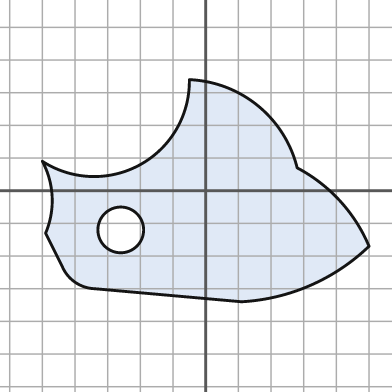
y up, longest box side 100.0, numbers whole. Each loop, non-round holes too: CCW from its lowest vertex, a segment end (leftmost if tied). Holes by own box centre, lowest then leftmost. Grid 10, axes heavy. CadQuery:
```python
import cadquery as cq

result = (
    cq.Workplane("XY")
    .moveTo(11.0, -34.0)
    .threePointArc((32.0, -29.0), (50.0, -17.0))
    .threePointArc((41.0, -3.0), (28.0, 7.0))
    .threePointArc((16.0, 26.0), (-5.0, 34.0))
    .threePointArc((-20.0, 8.0), (-50.0, 9.0))
    .threePointArc((-47.0, -2.0), (-49.0, -13.0))
    .lineTo(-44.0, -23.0)
    .threePointArc((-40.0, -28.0), (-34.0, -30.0))
    .close()
    .moveTo(-26.0, -12.0)
    .circle(7.0)
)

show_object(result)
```